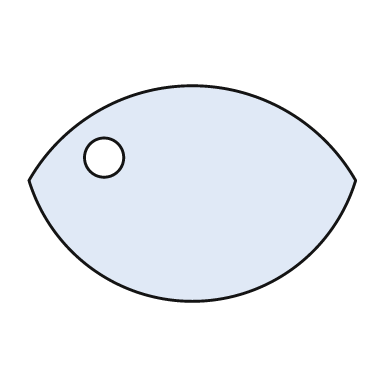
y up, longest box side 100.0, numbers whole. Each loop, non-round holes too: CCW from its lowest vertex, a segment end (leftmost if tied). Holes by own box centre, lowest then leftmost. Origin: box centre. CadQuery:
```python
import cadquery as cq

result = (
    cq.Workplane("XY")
    .moveTo(-50.0, 4.0)
    .threePointArc((0.0, -33.0), (50.0, 4.0))
    .threePointArc((0.0, 33.0), (-50.0, 4.0))
    .close()
    .moveTo(-27.0, 11.0)
    .circle(6.0)
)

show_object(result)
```